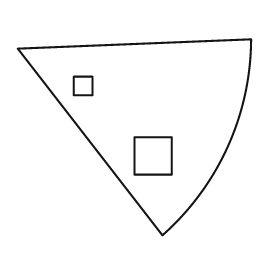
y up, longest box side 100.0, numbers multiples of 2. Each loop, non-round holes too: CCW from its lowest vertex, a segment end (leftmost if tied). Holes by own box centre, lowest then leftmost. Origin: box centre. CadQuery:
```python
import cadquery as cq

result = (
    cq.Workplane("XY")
    .moveTo(12.0, -42.0)
    .threePointArc((40.0, -4.0), (50.0, 42.0))
    .lineTo(-50.0, 38.0)
    .close()
    .moveTo(0.0, -16.0)
    .lineTo(16.0, -16.0)
    .lineTo(16.0, 0.0)
    .lineTo(0.0, 0.0)
    .close()
    .moveTo(-26.0, 18.0)
    .lineTo(-18.0, 18.0)
    .lineTo(-18.0, 26.0)
    .lineTo(-26.0, 26.0)
    .close()
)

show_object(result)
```